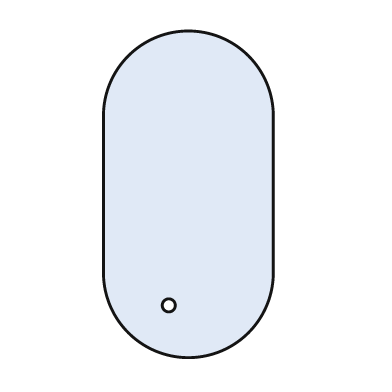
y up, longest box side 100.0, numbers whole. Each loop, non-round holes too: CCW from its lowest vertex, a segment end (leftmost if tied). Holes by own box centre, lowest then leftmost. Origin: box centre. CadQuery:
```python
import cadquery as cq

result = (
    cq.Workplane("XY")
    .moveTo(-26.0, -24.0)
    .threePointArc((0.0, -50.0), (26.0, -24.0))
    .lineTo(26.0, 24.0)
    .threePointArc((0.0, 50.0), (-26.0, 24.0))
    .close()
    .moveTo(-6.0, -34.0)
    .circle(2.0)
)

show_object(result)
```